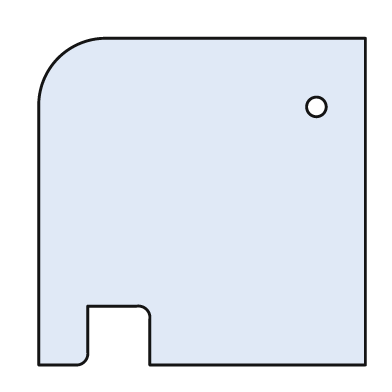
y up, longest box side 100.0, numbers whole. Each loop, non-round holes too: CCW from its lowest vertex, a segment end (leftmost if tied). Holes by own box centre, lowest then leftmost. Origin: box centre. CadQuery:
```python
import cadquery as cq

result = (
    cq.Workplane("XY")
    .moveTo(-50.0, -50.0)
    .lineTo(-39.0, -50.0)
    .threePointArc((-36.0, -49.0), (-35.0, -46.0))
    .lineTo(-35.0, -32.0)
    .lineTo(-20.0, -32.0)
    .threePointArc((-17.0, -33.0), (-16.0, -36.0))
    .lineTo(-16.0, -50.0)
    .lineTo(50.0, -50.0)
    .lineTo(50.0, 50.0)
    .lineTo(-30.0, 50.0)
    .threePointArc((-44.0, 44.0), (-50.0, 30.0))
    .close()
    .moveTo(35.0, 29.0)
    .circle(3.0)
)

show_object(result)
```